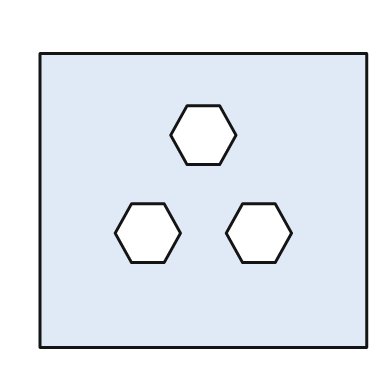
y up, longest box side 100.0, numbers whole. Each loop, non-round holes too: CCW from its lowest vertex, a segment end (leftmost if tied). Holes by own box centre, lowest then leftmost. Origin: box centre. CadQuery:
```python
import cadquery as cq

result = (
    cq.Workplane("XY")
    .moveTo(-50.0, -45.0)
    .lineTo(50.0, -45.0)
    .lineTo(50.0, 45.0)
    .lineTo(-50.0, 45.0)
    .close()
    .moveTo(-22.0, -19.0)
    .lineTo(-12.0, -19.0)
    .lineTo(-7.0, -10.0)
    .lineTo(-12.0, -1.0)
    .lineTo(-22.0, -1.0)
    .lineTo(-27.0, -10.0)
    .close()
    .moveTo(12.0, -19.0)
    .lineTo(22.0, -19.0)
    .lineTo(27.0, -10.0)
    .lineTo(22.0, -1.0)
    .lineTo(12.0, -1.0)
    .lineTo(7.0, -10.0)
    .close()
    .moveTo(-5.0, 11.0)
    .lineTo(5.0, 11.0)
    .lineTo(10.0, 20.0)
    .lineTo(5.0, 29.0)
    .lineTo(-5.0, 29.0)
    .lineTo(-10.0, 20.0)
    .close()
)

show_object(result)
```